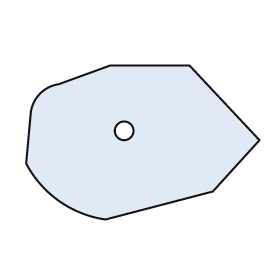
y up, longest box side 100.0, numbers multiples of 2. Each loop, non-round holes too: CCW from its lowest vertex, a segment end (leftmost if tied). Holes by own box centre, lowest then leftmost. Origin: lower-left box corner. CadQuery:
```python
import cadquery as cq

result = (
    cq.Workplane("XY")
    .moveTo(34.0, 0.0)
    .lineTo(80.0, 12.0)
    .lineTo(100.0, 34.0)
    .lineTo(70.0, 66.0)
    .lineTo(36.0, 66.0)
    .lineTo(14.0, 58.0)
    .threePointArc((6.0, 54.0), (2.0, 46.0))
    .lineTo(0.0, 24.0)
    .threePointArc((14.0, 8.0), (34.0, 0.0))
    .close()
    .moveTo(42.0, 38.0)
    .circle(4.0)
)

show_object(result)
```